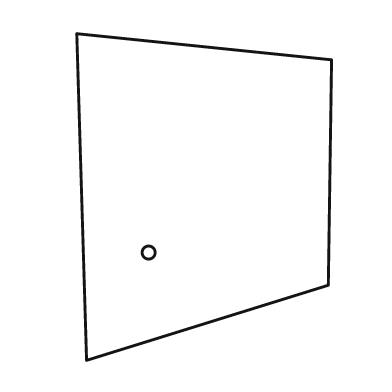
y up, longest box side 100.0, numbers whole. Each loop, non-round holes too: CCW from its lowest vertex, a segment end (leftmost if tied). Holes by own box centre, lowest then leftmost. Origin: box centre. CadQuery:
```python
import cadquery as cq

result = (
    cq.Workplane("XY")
    .moveTo(-36.0, -50.0)
    .lineTo(38.0, -27.0)
    .lineTo(39.0, 42.0)
    .lineTo(-39.0, 50.0)
    .close()
    .moveTo(-17.0, -17.0)
    .circle(2.0)
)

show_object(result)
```